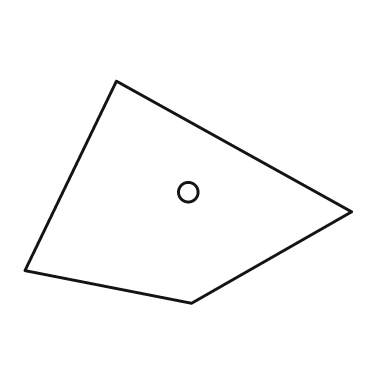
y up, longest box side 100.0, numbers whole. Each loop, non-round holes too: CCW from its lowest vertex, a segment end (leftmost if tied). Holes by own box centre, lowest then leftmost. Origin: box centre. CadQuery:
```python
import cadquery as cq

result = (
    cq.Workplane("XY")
    .moveTo(1.0, -34.0)
    .lineTo(50.0, -6.0)
    .lineTo(-22.0, 34.0)
    .lineTo(-50.0, -24.0)
    .close()
    .moveTo(0.0, 0.0)
    .circle(3.0)
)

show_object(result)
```